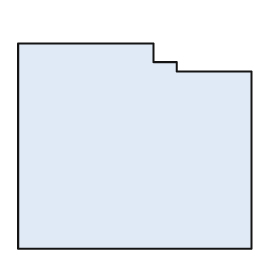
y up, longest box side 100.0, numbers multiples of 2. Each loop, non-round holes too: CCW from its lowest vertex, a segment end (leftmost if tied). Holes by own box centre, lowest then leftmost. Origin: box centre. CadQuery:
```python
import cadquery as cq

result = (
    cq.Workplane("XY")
    .moveTo(-50.0, -44.0)
    .lineTo(50.0, -44.0)
    .lineTo(50.0, 32.0)
    .lineTo(18.0, 32.0)
    .lineTo(18.0, 36.0)
    .lineTo(8.0, 36.0)
    .lineTo(8.0, 44.0)
    .lineTo(-50.0, 44.0)
    .close()
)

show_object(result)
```